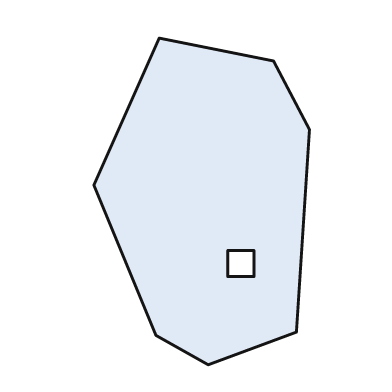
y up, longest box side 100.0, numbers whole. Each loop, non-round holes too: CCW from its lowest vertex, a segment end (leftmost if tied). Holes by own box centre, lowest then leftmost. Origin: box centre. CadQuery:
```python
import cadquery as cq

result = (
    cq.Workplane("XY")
    .moveTo(2.0, -50.0)
    .lineTo(29.0, -40.0)
    .lineTo(33.0, 22.0)
    .lineTo(22.0, 43.0)
    .lineTo(-13.0, 50.0)
    .lineTo(-33.0, 5.0)
    .lineTo(-14.0, -41.0)
    .close()
    .moveTo(8.0, -23.0)
    .lineTo(16.0, -23.0)
    .lineTo(16.0, -15.0)
    .lineTo(8.0, -15.0)
    .close()
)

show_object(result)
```